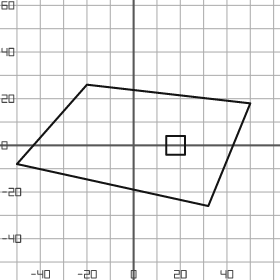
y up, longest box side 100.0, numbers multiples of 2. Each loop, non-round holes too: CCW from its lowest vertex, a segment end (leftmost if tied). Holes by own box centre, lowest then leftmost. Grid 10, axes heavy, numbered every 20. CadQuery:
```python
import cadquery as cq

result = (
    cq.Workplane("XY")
    .moveTo(32.0, -26.0)
    .lineTo(50.0, 18.0)
    .lineTo(-20.0, 26.0)
    .lineTo(-50.0, -8.0)
    .close()
    .moveTo(14.0, -4.0)
    .lineTo(22.0, -4.0)
    .lineTo(22.0, 4.0)
    .lineTo(14.0, 4.0)
    .close()
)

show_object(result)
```